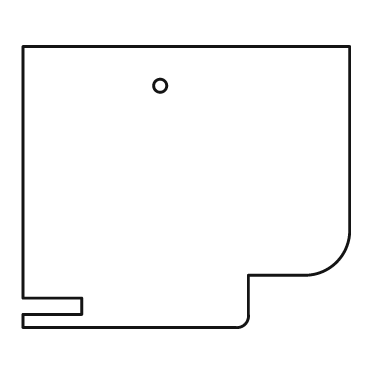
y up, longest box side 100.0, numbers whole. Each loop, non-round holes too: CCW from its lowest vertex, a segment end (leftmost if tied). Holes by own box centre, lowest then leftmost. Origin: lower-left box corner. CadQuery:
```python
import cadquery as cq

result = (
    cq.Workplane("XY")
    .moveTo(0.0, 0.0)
    .lineTo(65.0, 0.0)
    .threePointArc((68.0, 1.0), (69.0, 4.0))
    .lineTo(69.0, 16.0)
    .lineTo(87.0, 16.0)
    .threePointArc((96.0, 20.0), (100.0, 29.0))
    .lineTo(100.0, 86.0)
    .lineTo(0.0, 86.0)
    .lineTo(0.0, 9.0)
    .lineTo(18.0, 9.0)
    .lineTo(18.0, 4.0)
    .lineTo(0.0, 4.0)
    .close()
    .moveTo(42.0, 74.0)
    .circle(2.0)
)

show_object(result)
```